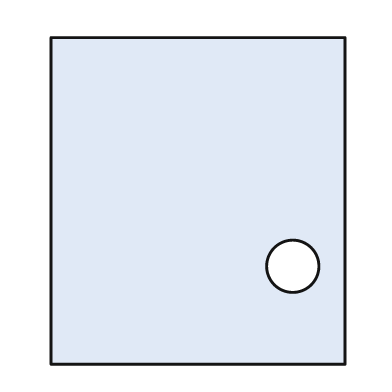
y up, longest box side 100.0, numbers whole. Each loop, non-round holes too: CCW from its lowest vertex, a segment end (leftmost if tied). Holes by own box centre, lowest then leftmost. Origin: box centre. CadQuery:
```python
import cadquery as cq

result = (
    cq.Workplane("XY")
    .moveTo(-45.0, -50.0)
    .lineTo(45.0, -50.0)
    .lineTo(45.0, 50.0)
    .lineTo(-45.0, 50.0)
    .close()
    .moveTo(29.0, -20.0)
    .circle(8.0)
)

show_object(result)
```